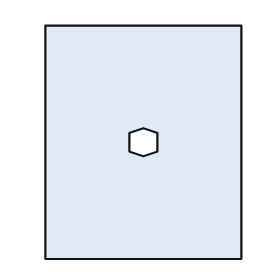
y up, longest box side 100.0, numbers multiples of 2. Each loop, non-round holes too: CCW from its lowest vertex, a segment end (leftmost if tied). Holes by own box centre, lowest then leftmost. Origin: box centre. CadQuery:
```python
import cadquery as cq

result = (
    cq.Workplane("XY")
    .moveTo(-42.0, -50.0)
    .lineTo(42.0, -50.0)
    .lineTo(42.0, 50.0)
    .lineTo(-42.0, 50.0)
    .close()
    .moveTo(0.0, -6.0)
    .lineTo(6.0, -4.0)
    .lineTo(6.0, 4.0)
    .lineTo(0.0, 6.0)
    .lineTo(-6.0, 4.0)
    .lineTo(-6.0, -4.0)
    .close()
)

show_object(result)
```